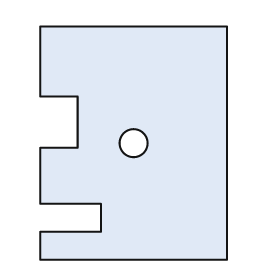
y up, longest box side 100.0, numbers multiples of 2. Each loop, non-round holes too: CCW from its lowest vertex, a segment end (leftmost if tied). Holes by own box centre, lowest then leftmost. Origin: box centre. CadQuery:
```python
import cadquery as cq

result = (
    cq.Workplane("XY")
    .moveTo(-40.0, -50.0)
    .lineTo(40.0, -50.0)
    .lineTo(40.0, 50.0)
    .lineTo(-40.0, 50.0)
    .lineTo(-40.0, 20.0)
    .lineTo(-24.0, 20.0)
    .lineTo(-24.0, -2.0)
    .lineTo(-40.0, -2.0)
    .lineTo(-40.0, -26.0)
    .lineTo(-14.0, -26.0)
    .lineTo(-14.0, -38.0)
    .lineTo(-40.0, -38.0)
    .close()
    .moveTo(0.0, 0.0)
    .circle(6.0)
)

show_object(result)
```